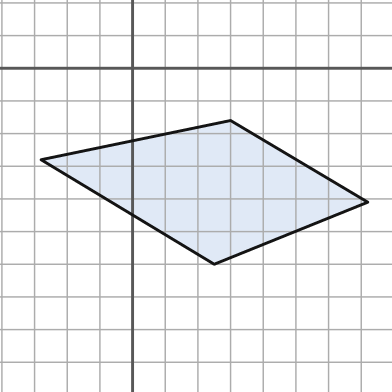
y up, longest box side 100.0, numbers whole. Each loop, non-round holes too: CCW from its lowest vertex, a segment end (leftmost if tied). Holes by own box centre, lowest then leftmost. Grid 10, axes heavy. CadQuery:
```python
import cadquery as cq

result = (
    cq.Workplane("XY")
    .moveTo(25.0, -60.0)
    .lineTo(72.0, -41.0)
    .lineTo(30.0, -16.0)
    .lineTo(-28.0, -28.0)
    .close()
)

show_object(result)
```